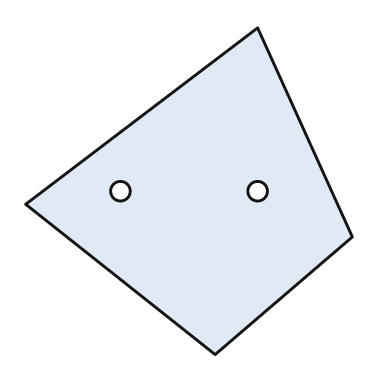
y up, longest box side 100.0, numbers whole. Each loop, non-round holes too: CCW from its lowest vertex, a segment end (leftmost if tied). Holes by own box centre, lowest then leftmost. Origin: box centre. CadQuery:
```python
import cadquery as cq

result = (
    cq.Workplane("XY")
    .moveTo(8.0, -50.0)
    .lineTo(50.0, -14.0)
    .lineTo(21.0, 50.0)
    .lineTo(-50.0, -4.0)
    .close()
    .moveTo(-21.0, 0.0)
    .circle(3.0)
    .moveTo(21.0, 0.0)
    .circle(3.0)
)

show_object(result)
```